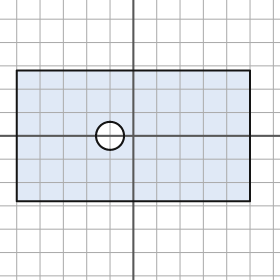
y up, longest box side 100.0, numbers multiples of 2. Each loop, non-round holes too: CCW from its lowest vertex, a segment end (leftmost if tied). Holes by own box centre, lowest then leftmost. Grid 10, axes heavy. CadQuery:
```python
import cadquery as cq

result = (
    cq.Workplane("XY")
    .moveTo(-50.0, -28.0)
    .lineTo(50.0, -28.0)
    .lineTo(50.0, 28.0)
    .lineTo(-50.0, 28.0)
    .close()
    .moveTo(-10.0, 0.0)
    .circle(6.0)
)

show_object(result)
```